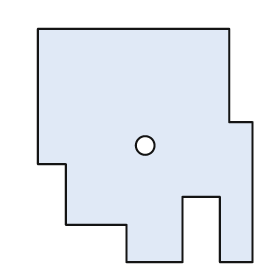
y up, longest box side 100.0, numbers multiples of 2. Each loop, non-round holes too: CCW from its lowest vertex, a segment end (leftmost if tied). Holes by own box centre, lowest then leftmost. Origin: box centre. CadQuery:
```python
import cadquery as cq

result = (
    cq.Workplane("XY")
    .moveTo(-8.0, -50.0)
    .lineTo(16.0, -50.0)
    .lineTo(16.0, -22.0)
    .lineTo(32.0, -22.0)
    .lineTo(32.0, -50.0)
    .lineTo(46.0, -50.0)
    .lineTo(46.0, 10.0)
    .lineTo(36.0, 10.0)
    .lineTo(36.0, 50.0)
    .lineTo(-46.0, 50.0)
    .lineTo(-46.0, -8.0)
    .lineTo(-34.0, -8.0)
    .lineTo(-34.0, -34.0)
    .lineTo(-8.0, -34.0)
    .close()
    .moveTo(0.0, 0.0)
    .circle(4.0)
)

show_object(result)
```